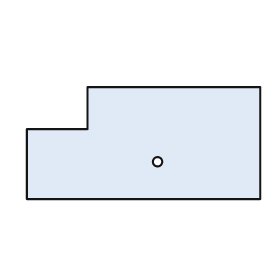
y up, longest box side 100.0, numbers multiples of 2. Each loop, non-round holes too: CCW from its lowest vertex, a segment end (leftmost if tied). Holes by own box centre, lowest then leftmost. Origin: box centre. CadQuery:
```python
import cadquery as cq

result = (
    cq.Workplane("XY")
    .moveTo(-50.0, -24.0)
    .lineTo(50.0, -24.0)
    .lineTo(50.0, 24.0)
    .lineTo(-24.0, 24.0)
    .lineTo(-24.0, 6.0)
    .lineTo(-50.0, 6.0)
    .close()
    .moveTo(6.0, -8.0)
    .circle(2.0)
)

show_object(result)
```